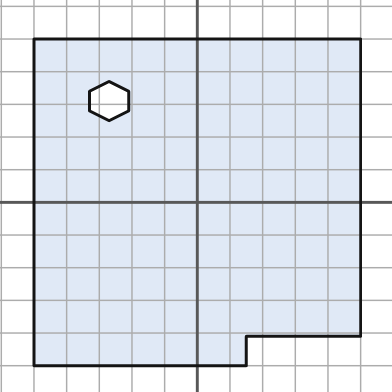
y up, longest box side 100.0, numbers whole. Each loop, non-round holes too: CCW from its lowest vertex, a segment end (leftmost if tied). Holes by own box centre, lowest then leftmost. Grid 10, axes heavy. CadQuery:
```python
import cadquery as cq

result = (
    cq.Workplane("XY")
    .moveTo(-50.0, -50.0)
    .lineTo(15.0, -50.0)
    .lineTo(15.0, -41.0)
    .lineTo(50.0, -41.0)
    .lineTo(50.0, 50.0)
    .lineTo(-50.0, 50.0)
    .close()
    .moveTo(-27.0, 25.0)
    .lineTo(-21.0, 28.0)
    .lineTo(-21.0, 34.0)
    .lineTo(-27.0, 37.0)
    .lineTo(-33.0, 34.0)
    .lineTo(-33.0, 28.0)
    .close()
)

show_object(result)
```